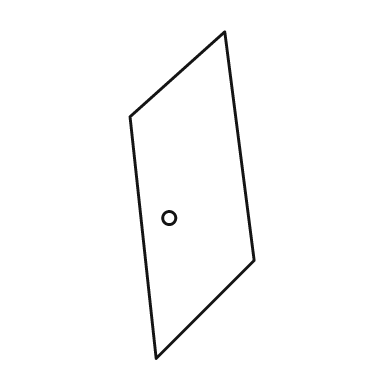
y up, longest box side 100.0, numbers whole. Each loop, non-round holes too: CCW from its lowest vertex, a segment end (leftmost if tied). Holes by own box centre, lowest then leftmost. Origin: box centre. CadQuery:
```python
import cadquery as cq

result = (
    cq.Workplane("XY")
    .moveTo(-11.0, -50.0)
    .lineTo(19.0, -20.0)
    .lineTo(10.0, 50.0)
    .lineTo(-19.0, 24.0)
    .close()
    .moveTo(-7.0, -7.0)
    .circle(2.0)
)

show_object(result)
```